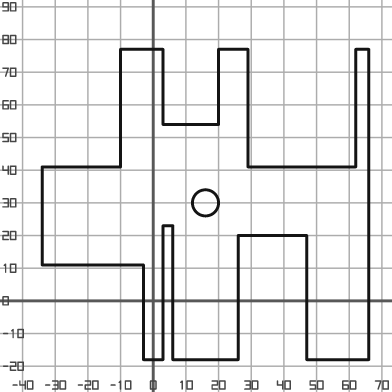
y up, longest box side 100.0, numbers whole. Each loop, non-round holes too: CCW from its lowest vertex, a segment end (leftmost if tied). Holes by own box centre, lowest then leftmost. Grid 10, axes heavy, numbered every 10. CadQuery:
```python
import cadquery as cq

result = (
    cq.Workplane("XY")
    .moveTo(-3.0, -18.0)
    .lineTo(3.0, -18.0)
    .lineTo(3.0, 23.0)
    .lineTo(6.0, 23.0)
    .lineTo(6.0, -18.0)
    .lineTo(26.0, -18.0)
    .lineTo(26.0, 20.0)
    .lineTo(47.0, 20.0)
    .lineTo(47.0, -18.0)
    .lineTo(66.0, -18.0)
    .lineTo(66.0, 77.0)
    .lineTo(62.0, 77.0)
    .lineTo(62.0, 41.0)
    .lineTo(29.0, 41.0)
    .lineTo(29.0, 77.0)
    .lineTo(20.0, 77.0)
    .lineTo(20.0, 54.0)
    .lineTo(3.0, 54.0)
    .lineTo(3.0, 77.0)
    .lineTo(-10.0, 77.0)
    .lineTo(-10.0, 41.0)
    .lineTo(-34.0, 41.0)
    .lineTo(-34.0, 11.0)
    .lineTo(-3.0, 11.0)
    .close()
    .moveTo(16.0, 30.0)
    .circle(4.0)
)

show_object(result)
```